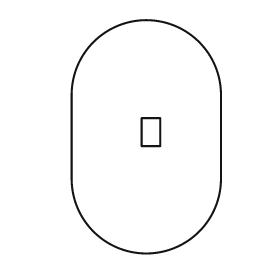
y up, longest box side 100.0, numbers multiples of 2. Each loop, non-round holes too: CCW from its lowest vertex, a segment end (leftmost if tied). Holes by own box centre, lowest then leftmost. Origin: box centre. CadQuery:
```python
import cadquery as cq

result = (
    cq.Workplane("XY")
    .moveTo(-32.0, -18.0)
    .threePointArc((0.0, -50.0), (32.0, -18.0))
    .lineTo(32.0, 18.0)
    .threePointArc((0.0, 50.0), (-32.0, 18.0))
    .close()
    .moveTo(-2.0, -4.0)
    .lineTo(6.0, -4.0)
    .lineTo(6.0, 8.0)
    .lineTo(-2.0, 8.0)
    .close()
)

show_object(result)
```